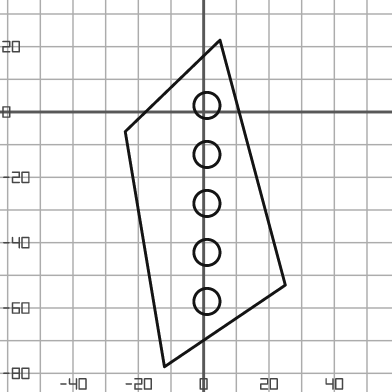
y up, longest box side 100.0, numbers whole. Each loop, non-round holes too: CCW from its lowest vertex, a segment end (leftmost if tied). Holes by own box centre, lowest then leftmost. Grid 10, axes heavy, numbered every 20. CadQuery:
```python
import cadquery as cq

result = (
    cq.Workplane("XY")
    .moveTo(-12.0, -78.0)
    .lineTo(25.0, -53.0)
    .lineTo(5.0, 22.0)
    .lineTo(-24.0, -6.0)
    .close()
    .moveTo(1.0, -58.0)
    .circle(4.0)
    .moveTo(1.0, -43.0)
    .circle(4.0)
    .moveTo(1.0, -28.0)
    .circle(4.0)
    .moveTo(1.0, -13.0)
    .circle(4.0)
    .moveTo(1.0, 2.0)
    .circle(4.0)
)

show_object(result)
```